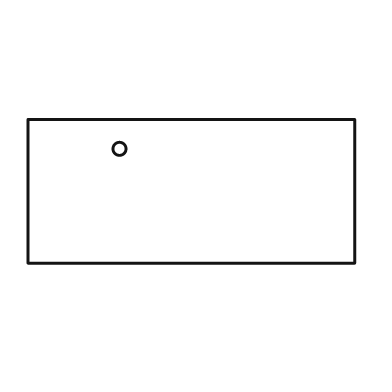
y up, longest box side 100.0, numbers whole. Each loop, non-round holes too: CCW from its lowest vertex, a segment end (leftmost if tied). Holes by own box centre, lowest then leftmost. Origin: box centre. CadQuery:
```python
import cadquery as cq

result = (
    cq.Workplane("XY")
    .moveTo(-50.0, -22.0)
    .lineTo(50.0, -22.0)
    .lineTo(50.0, 22.0)
    .lineTo(-50.0, 22.0)
    .close()
    .moveTo(-22.0, 13.0)
    .circle(2.0)
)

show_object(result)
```